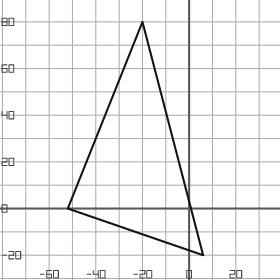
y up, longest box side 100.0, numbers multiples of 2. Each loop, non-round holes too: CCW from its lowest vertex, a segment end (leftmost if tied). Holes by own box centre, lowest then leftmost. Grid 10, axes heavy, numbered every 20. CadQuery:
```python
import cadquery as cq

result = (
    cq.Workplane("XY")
    .moveTo(6.0, -20.0)
    .lineTo(-20.0, 80.0)
    .lineTo(-52.0, 0.0)
    .close()
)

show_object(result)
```